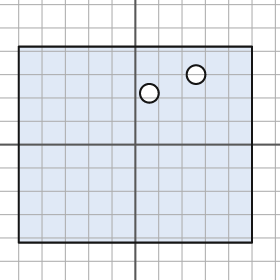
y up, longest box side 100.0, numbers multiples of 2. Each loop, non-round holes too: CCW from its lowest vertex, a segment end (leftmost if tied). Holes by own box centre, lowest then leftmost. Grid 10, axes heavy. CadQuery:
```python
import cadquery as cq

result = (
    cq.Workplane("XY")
    .moveTo(-50.0, -42.0)
    .lineTo(50.0, -42.0)
    .lineTo(50.0, 42.0)
    .lineTo(-50.0, 42.0)
    .close()
    .moveTo(6.0, 22.0)
    .circle(4.0)
    .moveTo(26.0, 30.0)
    .circle(4.0)
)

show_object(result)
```